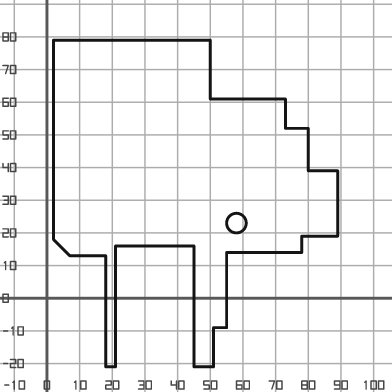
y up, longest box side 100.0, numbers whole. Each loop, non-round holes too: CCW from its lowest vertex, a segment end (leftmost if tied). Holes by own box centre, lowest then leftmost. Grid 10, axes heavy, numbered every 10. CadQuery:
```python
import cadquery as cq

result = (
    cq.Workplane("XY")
    .moveTo(18.0, -21.0)
    .lineTo(21.0, -21.0)
    .lineTo(21.0, 16.0)
    .lineTo(45.0, 16.0)
    .lineTo(45.0, -21.0)
    .lineTo(51.0, -21.0)
    .lineTo(51.0, -9.0)
    .lineTo(55.0, -9.0)
    .lineTo(55.0, 14.0)
    .lineTo(78.0, 14.0)
    .lineTo(78.0, 19.0)
    .lineTo(89.0, 19.0)
    .lineTo(89.0, 39.0)
    .lineTo(80.0, 39.0)
    .lineTo(80.0, 52.0)
    .lineTo(73.0, 52.0)
    .lineTo(73.0, 61.0)
    .lineTo(50.0, 61.0)
    .lineTo(50.0, 79.0)
    .lineTo(2.0, 79.0)
    .lineTo(2.0, 18.0)
    .lineTo(7.0, 13.0)
    .lineTo(18.0, 13.0)
    .close()
    .moveTo(58.0, 23.0)
    .circle(3.0)
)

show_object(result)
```